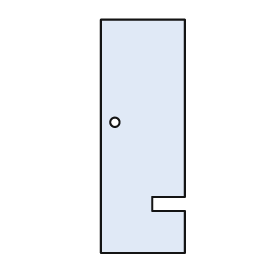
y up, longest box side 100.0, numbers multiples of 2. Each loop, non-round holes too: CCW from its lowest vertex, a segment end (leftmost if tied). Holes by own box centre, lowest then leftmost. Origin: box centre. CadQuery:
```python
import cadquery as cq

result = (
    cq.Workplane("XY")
    .moveTo(-18.0, -50.0)
    .lineTo(18.0, -50.0)
    .lineTo(18.0, -32.0)
    .lineTo(4.0, -32.0)
    .lineTo(4.0, -26.0)
    .lineTo(18.0, -26.0)
    .lineTo(18.0, 50.0)
    .lineTo(-18.0, 50.0)
    .close()
    .moveTo(-12.0, 6.0)
    .circle(2.0)
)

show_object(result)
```